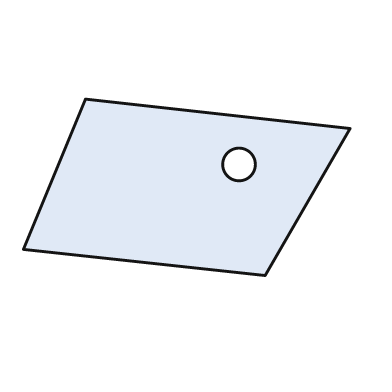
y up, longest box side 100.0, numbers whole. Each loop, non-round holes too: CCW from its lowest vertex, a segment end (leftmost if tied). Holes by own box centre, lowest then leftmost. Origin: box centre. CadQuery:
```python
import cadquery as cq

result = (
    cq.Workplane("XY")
    .moveTo(24.0, -27.0)
    .lineTo(50.0, 18.0)
    .lineTo(-31.0, 27.0)
    .lineTo(-50.0, -19.0)
    .close()
    .moveTo(16.0, 7.0)
    .circle(5.0)
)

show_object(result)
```